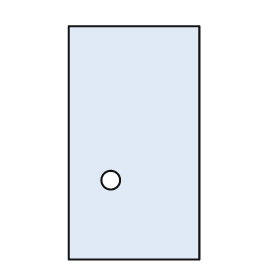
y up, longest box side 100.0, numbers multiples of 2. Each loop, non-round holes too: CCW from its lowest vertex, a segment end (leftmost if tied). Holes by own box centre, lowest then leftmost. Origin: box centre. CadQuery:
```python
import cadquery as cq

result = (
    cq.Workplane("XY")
    .moveTo(-28.0, -50.0)
    .lineTo(28.0, -50.0)
    .lineTo(28.0, 50.0)
    .lineTo(-28.0, 50.0)
    .close()
    .moveTo(-10.0, -16.0)
    .circle(4.0)
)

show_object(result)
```